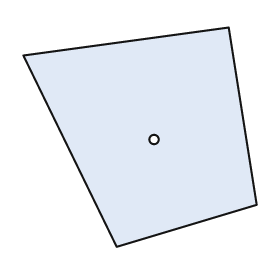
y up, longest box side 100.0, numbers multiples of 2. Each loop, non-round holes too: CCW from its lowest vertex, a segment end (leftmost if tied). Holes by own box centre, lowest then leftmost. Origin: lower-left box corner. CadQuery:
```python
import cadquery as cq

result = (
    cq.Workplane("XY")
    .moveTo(40.0, 0.0)
    .lineTo(100.0, 18.0)
    .lineTo(88.0, 94.0)
    .lineTo(0.0, 82.0)
    .close()
    .moveTo(56.0, 46.0)
    .circle(2.0)
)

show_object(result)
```